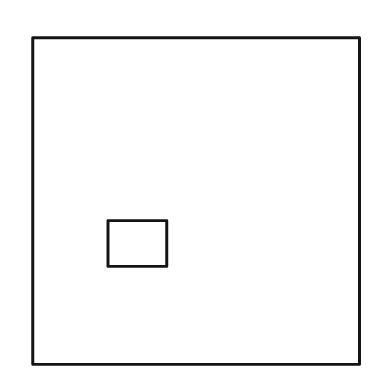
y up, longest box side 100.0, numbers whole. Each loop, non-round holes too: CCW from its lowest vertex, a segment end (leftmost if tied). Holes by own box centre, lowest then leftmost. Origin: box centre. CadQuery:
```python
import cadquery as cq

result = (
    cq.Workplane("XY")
    .moveTo(-50.0, -50.0)
    .lineTo(50.0, -50.0)
    .lineTo(50.0, 50.0)
    .lineTo(-50.0, 50.0)
    .close()
    .moveTo(-27.0, -20.0)
    .lineTo(-9.0, -20.0)
    .lineTo(-9.0, -6.0)
    .lineTo(-27.0, -6.0)
    .close()
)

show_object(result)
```